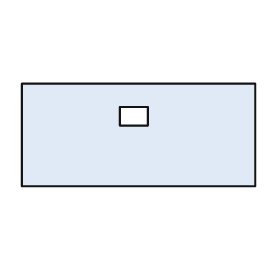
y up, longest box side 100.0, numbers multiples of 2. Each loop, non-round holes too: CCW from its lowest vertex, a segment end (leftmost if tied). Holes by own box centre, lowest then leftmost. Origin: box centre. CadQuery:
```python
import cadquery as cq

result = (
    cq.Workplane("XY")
    .moveTo(-50.0, -22.0)
    .lineTo(50.0, -22.0)
    .lineTo(50.0, 22.0)
    .lineTo(-50.0, 22.0)
    .close()
    .moveTo(-8.0, 4.0)
    .lineTo(4.0, 4.0)
    .lineTo(4.0, 12.0)
    .lineTo(-8.0, 12.0)
    .close()
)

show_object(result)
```